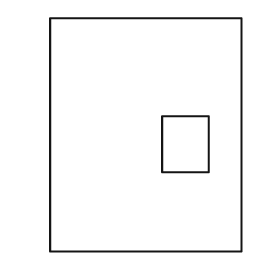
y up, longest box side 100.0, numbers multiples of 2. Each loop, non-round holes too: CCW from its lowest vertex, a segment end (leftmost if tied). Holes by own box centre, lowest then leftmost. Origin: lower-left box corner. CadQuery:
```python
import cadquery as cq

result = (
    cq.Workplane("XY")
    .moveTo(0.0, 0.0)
    .lineTo(82.0, 0.0)
    .lineTo(82.0, 100.0)
    .lineTo(0.0, 100.0)
    .close()
    .moveTo(48.0, 34.0)
    .lineTo(68.0, 34.0)
    .lineTo(68.0, 58.0)
    .lineTo(48.0, 58.0)
    .close()
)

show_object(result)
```